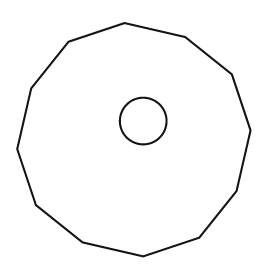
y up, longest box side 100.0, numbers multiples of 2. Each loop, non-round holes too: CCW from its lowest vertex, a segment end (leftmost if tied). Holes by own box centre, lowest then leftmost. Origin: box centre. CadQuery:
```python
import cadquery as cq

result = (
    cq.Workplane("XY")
    .moveTo(4.0, -50.0)
    .lineTo(28.0, -42.0)
    .lineTo(44.0, -22.0)
    .lineTo(50.0, 4.0)
    .lineTo(42.0, 28.0)
    .lineTo(22.0, 44.0)
    .lineTo(-4.0, 50.0)
    .lineTo(-28.0, 42.0)
    .lineTo(-44.0, 22.0)
    .lineTo(-50.0, -4.0)
    .lineTo(-42.0, -28.0)
    .lineTo(-22.0, -44.0)
    .close()
    .moveTo(4.0, 8.0)
    .circle(10.0)
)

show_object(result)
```